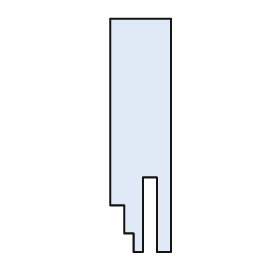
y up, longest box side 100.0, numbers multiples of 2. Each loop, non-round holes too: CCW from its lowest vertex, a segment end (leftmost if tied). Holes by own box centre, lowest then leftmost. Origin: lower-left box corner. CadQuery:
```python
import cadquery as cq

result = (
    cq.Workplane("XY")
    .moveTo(10.0, 0.0)
    .lineTo(14.0, 0.0)
    .lineTo(14.0, 32.0)
    .lineTo(20.0, 32.0)
    .lineTo(20.0, 0.0)
    .lineTo(26.0, 0.0)
    .lineTo(26.0, 100.0)
    .lineTo(0.0, 100.0)
    .lineTo(0.0, 20.0)
    .lineTo(6.0, 20.0)
    .lineTo(6.0, 8.0)
    .lineTo(10.0, 8.0)
    .close()
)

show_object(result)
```